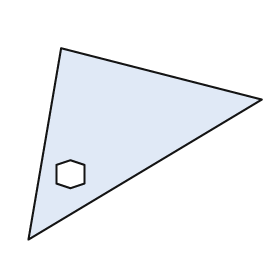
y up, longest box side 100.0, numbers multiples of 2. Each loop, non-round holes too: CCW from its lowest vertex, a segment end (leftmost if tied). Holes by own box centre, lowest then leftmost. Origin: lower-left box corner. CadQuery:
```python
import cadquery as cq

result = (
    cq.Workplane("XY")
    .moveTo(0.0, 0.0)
    .lineTo(100.0, 60.0)
    .lineTo(14.0, 82.0)
    .close()
    .moveTo(18.0, 22.0)
    .lineTo(24.0, 24.0)
    .lineTo(24.0, 32.0)
    .lineTo(18.0, 34.0)
    .lineTo(12.0, 32.0)
    .lineTo(12.0, 24.0)
    .close()
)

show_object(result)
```